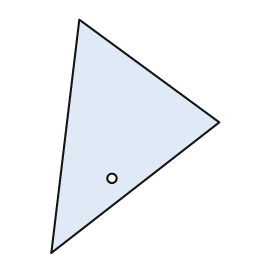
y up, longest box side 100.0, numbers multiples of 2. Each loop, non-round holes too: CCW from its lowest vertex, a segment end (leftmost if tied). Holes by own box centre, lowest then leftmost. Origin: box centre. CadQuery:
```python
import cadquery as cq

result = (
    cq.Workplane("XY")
    .moveTo(-36.0, -50.0)
    .lineTo(36.0, 6.0)
    .lineTo(-24.0, 50.0)
    .close()
    .moveTo(-10.0, -18.0)
    .circle(2.0)
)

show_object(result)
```